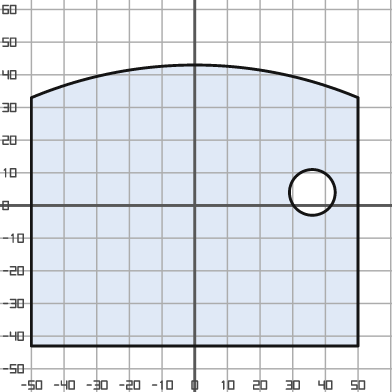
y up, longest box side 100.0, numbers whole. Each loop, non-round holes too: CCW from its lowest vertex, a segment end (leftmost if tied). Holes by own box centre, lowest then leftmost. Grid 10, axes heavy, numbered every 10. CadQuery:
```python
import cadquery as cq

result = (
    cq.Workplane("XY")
    .moveTo(-50.0, -43.0)
    .lineTo(50.0, -43.0)
    .lineTo(50.0, 33.0)
    .threePointArc((0.0, 43.0), (-50.0, 33.0))
    .close()
    .moveTo(36.0, 4.0)
    .circle(7.0)
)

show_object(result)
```